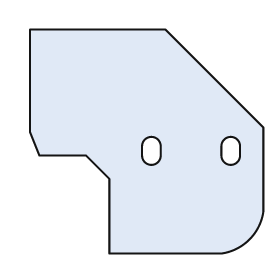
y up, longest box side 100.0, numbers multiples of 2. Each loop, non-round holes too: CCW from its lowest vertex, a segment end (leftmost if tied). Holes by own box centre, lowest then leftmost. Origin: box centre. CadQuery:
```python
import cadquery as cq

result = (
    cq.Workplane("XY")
    .moveTo(-16.0, -48.0)
    .lineTo(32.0, -48.0)
    .threePointArc((44.0, -42.0), (50.0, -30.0))
    .lineTo(50.0, 6.0)
    .lineTo(8.0, 48.0)
    .lineTo(-50.0, 48.0)
    .lineTo(-50.0, 4.0)
    .lineTo(-46.0, -6.0)
    .lineTo(-26.0, -6.0)
    .lineTo(-16.0, -16.0)
    .close()
    .moveTo(-2.0, -6.0)
    .threePointArc((2.0, -10.0), (6.0, -6.0))
    .lineTo(6.0, -2.0)
    .threePointArc((2.0, 2.0), (-2.0, -2.0))
    .close()
    .moveTo(32.0, -6.0)
    .threePointArc((36.0, -10.0), (40.0, -6.0))
    .lineTo(40.0, -2.0)
    .threePointArc((36.0, 2.0), (32.0, -2.0))
    .close()
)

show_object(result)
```